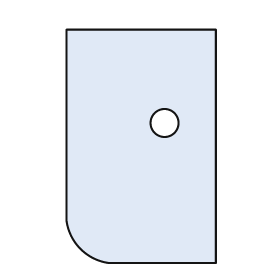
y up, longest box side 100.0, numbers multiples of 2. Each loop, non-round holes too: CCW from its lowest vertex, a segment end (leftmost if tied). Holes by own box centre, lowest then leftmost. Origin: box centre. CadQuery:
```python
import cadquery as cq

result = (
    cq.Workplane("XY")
    .moveTo(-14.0, -50.0)
    .lineTo(32.0, -50.0)
    .lineTo(32.0, 50.0)
    .lineTo(-32.0, 50.0)
    .lineTo(-32.0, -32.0)
    .threePointArc((-26.0, -44.0), (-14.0, -50.0))
    .close()
    .moveTo(10.0, 10.0)
    .circle(6.0)
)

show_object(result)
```